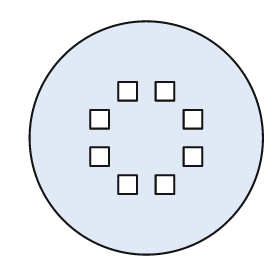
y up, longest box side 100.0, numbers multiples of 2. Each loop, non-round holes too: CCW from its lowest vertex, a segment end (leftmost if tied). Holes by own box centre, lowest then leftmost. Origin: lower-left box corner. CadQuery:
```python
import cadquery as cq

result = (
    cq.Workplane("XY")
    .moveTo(50.0, 50.0)
    .circle(50.0)
    .moveTo(38.0, 26.0)
    .lineTo(46.0, 26.0)
    .lineTo(46.0, 34.0)
    .lineTo(38.0, 34.0)
    .close()
    .moveTo(54.0, 26.0)
    .lineTo(62.0, 26.0)
    .lineTo(62.0, 34.0)
    .lineTo(54.0, 34.0)
    .close()
    .moveTo(26.0, 38.0)
    .lineTo(34.0, 38.0)
    .lineTo(34.0, 46.0)
    .lineTo(26.0, 46.0)
    .close()
    .moveTo(66.0, 38.0)
    .lineTo(74.0, 38.0)
    .lineTo(74.0, 46.0)
    .lineTo(66.0, 46.0)
    .close()
    .moveTo(26.0, 54.0)
    .lineTo(34.0, 54.0)
    .lineTo(34.0, 62.0)
    .lineTo(26.0, 62.0)
    .close()
    .moveTo(66.0, 54.0)
    .lineTo(74.0, 54.0)
    .lineTo(74.0, 62.0)
    .lineTo(66.0, 62.0)
    .close()
    .moveTo(38.0, 66.0)
    .lineTo(46.0, 66.0)
    .lineTo(46.0, 74.0)
    .lineTo(38.0, 74.0)
    .close()
    .moveTo(54.0, 66.0)
    .lineTo(62.0, 66.0)
    .lineTo(62.0, 74.0)
    .lineTo(54.0, 74.0)
    .close()
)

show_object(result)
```